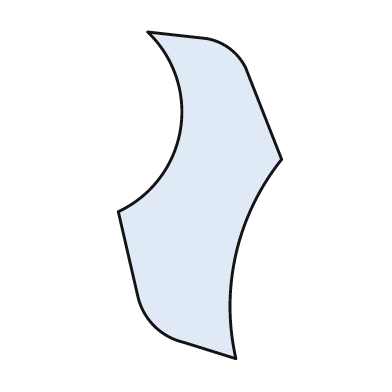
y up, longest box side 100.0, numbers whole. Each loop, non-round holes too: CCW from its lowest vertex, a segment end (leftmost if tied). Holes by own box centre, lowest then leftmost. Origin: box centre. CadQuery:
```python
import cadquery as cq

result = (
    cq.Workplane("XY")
    .moveTo(11.0, -50.0)
    .threePointArc((11.0, -18.0), (25.0, 11.0))
    .lineTo(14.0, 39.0)
    .threePointArc((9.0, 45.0), (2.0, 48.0))
    .lineTo(-16.0, 50.0)
    .threePointArc((-6.0, 20.0), (-25.0, -5.0))
    .lineTo(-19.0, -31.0)
    .threePointArc((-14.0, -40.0), (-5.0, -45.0))
    .close()
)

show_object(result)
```